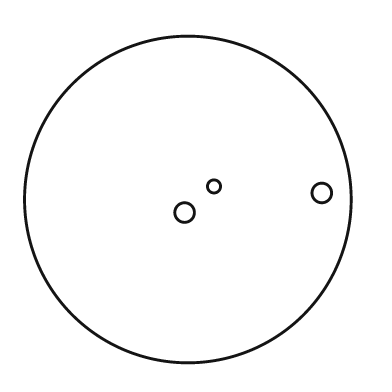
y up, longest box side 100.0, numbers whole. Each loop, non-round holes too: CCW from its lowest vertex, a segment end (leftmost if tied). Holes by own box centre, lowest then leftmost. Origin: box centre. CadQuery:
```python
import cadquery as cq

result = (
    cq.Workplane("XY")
    .moveTo(0.0, 0.0)
    .circle(50.0)
    .moveTo(-1.0, -4.0)
    .circle(3.0)
    .moveTo(41.0, 2.0)
    .circle(3.0)
    .moveTo(8.0, 4.0)
    .circle(2.0)
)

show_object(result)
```